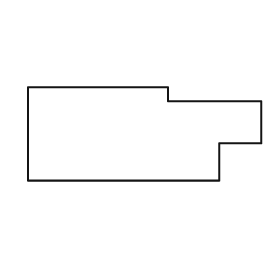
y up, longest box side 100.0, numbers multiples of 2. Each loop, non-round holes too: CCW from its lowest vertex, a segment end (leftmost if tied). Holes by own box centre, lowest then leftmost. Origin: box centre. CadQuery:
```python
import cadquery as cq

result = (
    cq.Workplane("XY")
    .moveTo(-50.0, -20.0)
    .lineTo(32.0, -20.0)
    .lineTo(32.0, -4.0)
    .lineTo(50.0, -4.0)
    .lineTo(50.0, 14.0)
    .lineTo(10.0, 14.0)
    .lineTo(10.0, 20.0)
    .lineTo(-50.0, 20.0)
    .close()
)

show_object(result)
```